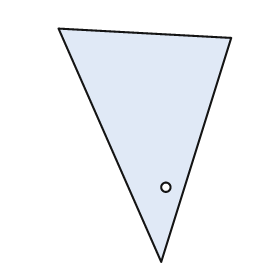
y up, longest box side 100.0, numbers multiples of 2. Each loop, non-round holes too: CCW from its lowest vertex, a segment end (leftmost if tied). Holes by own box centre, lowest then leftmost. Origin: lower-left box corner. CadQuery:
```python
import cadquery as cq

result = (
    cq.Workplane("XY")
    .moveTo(44.0, 0.0)
    .lineTo(74.0, 96.0)
    .lineTo(0.0, 100.0)
    .close()
    .moveTo(46.0, 32.0)
    .circle(2.0)
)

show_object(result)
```